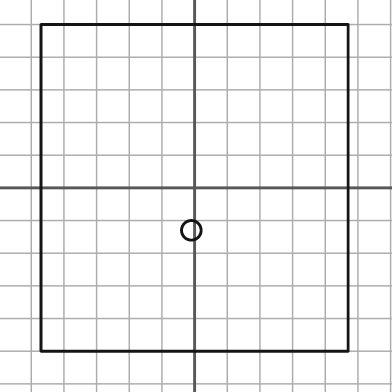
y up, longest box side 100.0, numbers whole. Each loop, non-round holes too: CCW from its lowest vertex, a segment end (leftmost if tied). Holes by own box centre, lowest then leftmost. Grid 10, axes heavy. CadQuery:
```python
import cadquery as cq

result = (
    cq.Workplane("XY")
    .moveTo(-47.0, -50.0)
    .lineTo(47.0, -50.0)
    .lineTo(47.0, 50.0)
    .lineTo(-47.0, 50.0)
    .close()
    .moveTo(-1.0, -13.0)
    .circle(3.0)
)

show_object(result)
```